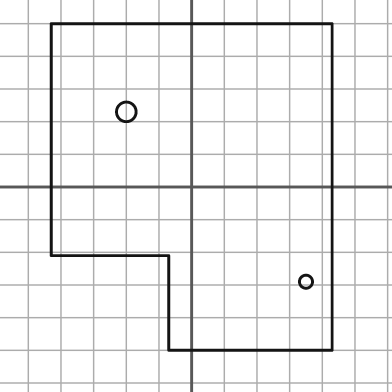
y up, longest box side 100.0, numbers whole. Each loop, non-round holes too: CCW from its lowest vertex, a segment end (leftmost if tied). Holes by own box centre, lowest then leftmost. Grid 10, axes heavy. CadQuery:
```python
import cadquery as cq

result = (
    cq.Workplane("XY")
    .moveTo(-7.0, -50.0)
    .lineTo(43.0, -50.0)
    .lineTo(43.0, 50.0)
    .lineTo(-43.0, 50.0)
    .lineTo(-43.0, -21.0)
    .lineTo(-7.0, -21.0)
    .close()
    .moveTo(35.0, -29.0)
    .circle(2.0)
    .moveTo(-20.0, 23.0)
    .circle(3.0)
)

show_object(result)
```